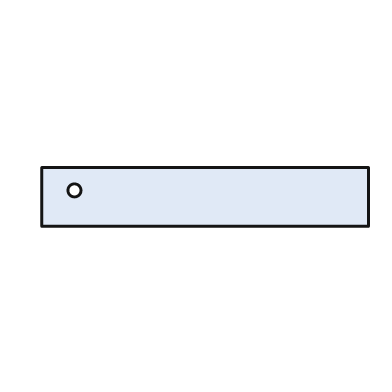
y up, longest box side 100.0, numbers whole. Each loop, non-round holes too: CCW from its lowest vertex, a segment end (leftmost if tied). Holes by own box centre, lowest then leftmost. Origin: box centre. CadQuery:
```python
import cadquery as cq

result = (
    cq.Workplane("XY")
    .moveTo(-50.0, -9.0)
    .lineTo(50.0, -9.0)
    .lineTo(50.0, 9.0)
    .lineTo(-50.0, 9.0)
    .close()
    .moveTo(-40.0, 2.0)
    .circle(2.0)
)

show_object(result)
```